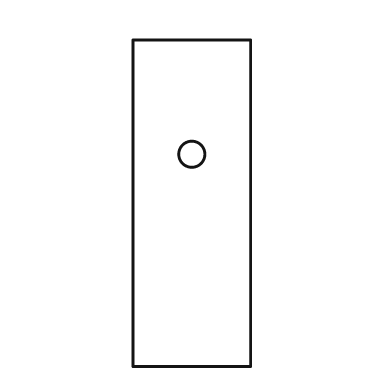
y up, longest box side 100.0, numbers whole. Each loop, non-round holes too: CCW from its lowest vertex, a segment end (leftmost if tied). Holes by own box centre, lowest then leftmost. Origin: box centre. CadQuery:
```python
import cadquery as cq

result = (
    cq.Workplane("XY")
    .moveTo(-18.0, -50.0)
    .lineTo(18.0, -50.0)
    .lineTo(18.0, 50.0)
    .lineTo(-18.0, 50.0)
    .close()
    .moveTo(0.0, 15.0)
    .circle(4.0)
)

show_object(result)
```